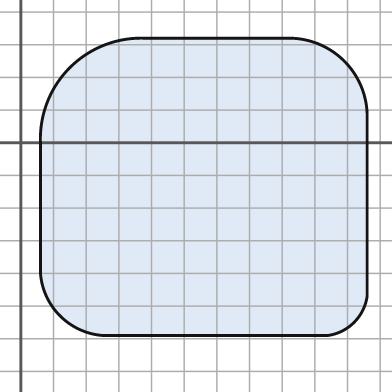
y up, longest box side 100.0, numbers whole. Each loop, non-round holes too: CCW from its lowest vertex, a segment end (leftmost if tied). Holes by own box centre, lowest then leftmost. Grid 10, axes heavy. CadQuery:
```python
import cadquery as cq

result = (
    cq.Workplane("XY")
    .moveTo(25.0, -59.0)
    .lineTo(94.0, -59.0)
    .threePointArc((102.0, -55.0), (106.0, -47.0))
    .lineTo(106.0, 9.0)
    .threePointArc((99.0, 25.0), (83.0, 32.0))
    .lineTo(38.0, 32.0)
    .threePointArc((15.0, 23.0), (6.0, 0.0))
    .lineTo(6.0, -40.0)
    .threePointArc((12.0, -53.0), (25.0, -59.0))
    .close()
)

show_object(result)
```